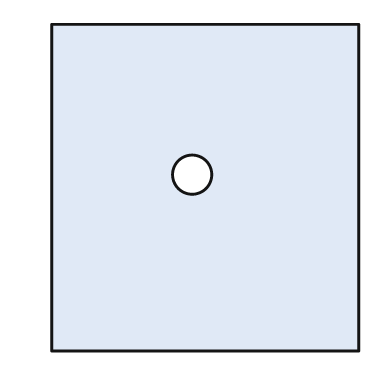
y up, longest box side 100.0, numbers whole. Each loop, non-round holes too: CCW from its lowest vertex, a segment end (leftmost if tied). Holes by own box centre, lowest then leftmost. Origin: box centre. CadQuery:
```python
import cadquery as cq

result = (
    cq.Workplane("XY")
    .moveTo(-47.0, -50.0)
    .lineTo(47.0, -50.0)
    .lineTo(47.0, 50.0)
    .lineTo(-47.0, 50.0)
    .close()
    .moveTo(-4.0, 4.0)
    .circle(6.0)
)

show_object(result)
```